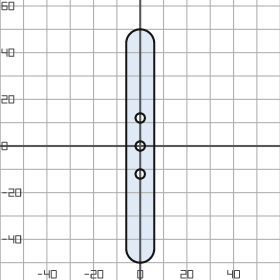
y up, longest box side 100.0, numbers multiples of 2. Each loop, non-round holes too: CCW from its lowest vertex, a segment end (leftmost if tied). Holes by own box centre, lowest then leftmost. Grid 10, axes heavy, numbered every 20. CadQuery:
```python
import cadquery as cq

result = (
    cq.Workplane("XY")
    .moveTo(-6.0, -44.0)
    .threePointArc((0.0, -50.0), (6.0, -44.0))
    .lineTo(6.0, 44.0)
    .threePointArc((0.0, 50.0), (-6.0, 44.0))
    .close()
    .moveTo(0.0, -12.0)
    .circle(2.0)
    .moveTo(0.0, 0.0)
    .circle(2.0)
    .moveTo(0.0, 12.0)
    .circle(2.0)
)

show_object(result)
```